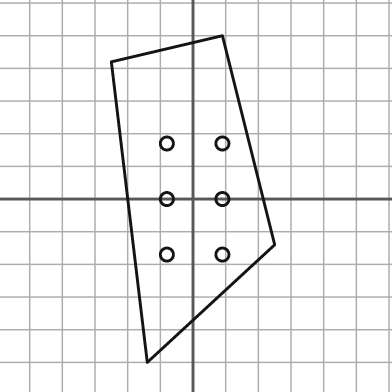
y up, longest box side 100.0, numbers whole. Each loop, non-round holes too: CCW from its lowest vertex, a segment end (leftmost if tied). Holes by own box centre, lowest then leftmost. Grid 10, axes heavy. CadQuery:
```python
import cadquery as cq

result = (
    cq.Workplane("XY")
    .moveTo(-14.0, -50.0)
    .lineTo(25.0, -14.0)
    .lineTo(9.0, 50.0)
    .lineTo(-25.0, 42.0)
    .close()
    .moveTo(-8.0, -17.0)
    .circle(2.0)
    .moveTo(9.0, -17.0)
    .circle(2.0)
    .moveTo(-8.0, 0.0)
    .circle(2.0)
    .moveTo(9.0, 0.0)
    .circle(2.0)
    .moveTo(-8.0, 17.0)
    .circle(2.0)
    .moveTo(9.0, 17.0)
    .circle(2.0)
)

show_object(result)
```